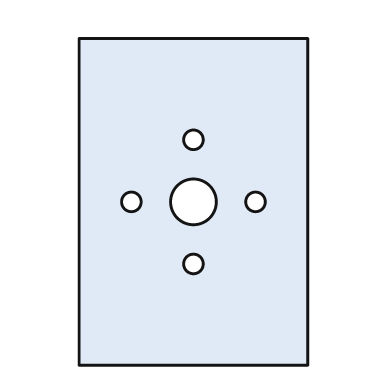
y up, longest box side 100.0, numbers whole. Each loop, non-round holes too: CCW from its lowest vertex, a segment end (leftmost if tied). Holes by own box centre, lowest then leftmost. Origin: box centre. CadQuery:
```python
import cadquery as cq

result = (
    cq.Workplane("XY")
    .moveTo(-35.0, -50.0)
    .lineTo(35.0, -50.0)
    .lineTo(35.0, 50.0)
    .lineTo(-35.0, 50.0)
    .close()
    .moveTo(0.0, -19.0)
    .circle(3.0)
    .moveTo(-19.0, 0.0)
    .circle(3.0)
    .moveTo(0.0, 0.0)
    .circle(7.0)
    .moveTo(19.0, 0.0)
    .circle(3.0)
    .moveTo(0.0, 19.0)
    .circle(3.0)
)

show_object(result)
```